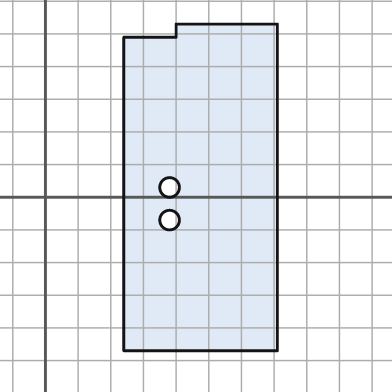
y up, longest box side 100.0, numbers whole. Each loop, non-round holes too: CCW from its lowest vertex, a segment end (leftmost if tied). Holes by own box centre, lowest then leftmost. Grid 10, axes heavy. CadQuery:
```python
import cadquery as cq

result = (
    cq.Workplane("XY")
    .moveTo(24.0, -47.0)
    .lineTo(71.0, -47.0)
    .lineTo(71.0, 53.0)
    .lineTo(40.0, 53.0)
    .lineTo(40.0, 49.0)
    .lineTo(24.0, 49.0)
    .close()
    .moveTo(38.0, -7.0)
    .circle(3.0)
    .moveTo(38.0, 3.0)
    .circle(3.0)
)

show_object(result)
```